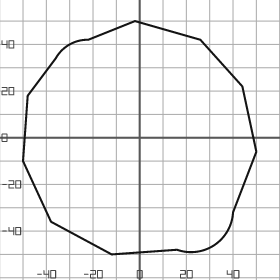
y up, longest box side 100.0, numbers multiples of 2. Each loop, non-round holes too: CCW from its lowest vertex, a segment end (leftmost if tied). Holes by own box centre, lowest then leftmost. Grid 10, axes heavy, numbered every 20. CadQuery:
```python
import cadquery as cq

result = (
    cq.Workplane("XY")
    .moveTo(-12.0, -50.0)
    .lineTo(16.0, -48.0)
    .threePointArc((32.0, -46.0), (40.0, -32.0))
    .lineTo(50.0, -6.0)
    .lineTo(44.0, 22.0)
    .lineTo(26.0, 42.0)
    .lineTo(-2.0, 50.0)
    .lineTo(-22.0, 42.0)
    .threePointArc((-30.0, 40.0), (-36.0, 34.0))
    .lineTo(-48.0, 18.0)
    .lineTo(-50.0, -10.0)
    .lineTo(-38.0, -36.0)
    .close()
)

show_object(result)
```